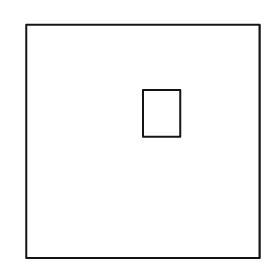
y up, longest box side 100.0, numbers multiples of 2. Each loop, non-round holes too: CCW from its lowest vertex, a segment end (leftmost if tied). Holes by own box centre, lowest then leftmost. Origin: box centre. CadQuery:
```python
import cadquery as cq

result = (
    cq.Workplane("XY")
    .moveTo(-50.0, -50.0)
    .lineTo(50.0, -50.0)
    .lineTo(50.0, 50.0)
    .lineTo(-50.0, 50.0)
    .close()
    .moveTo(0.0, 2.0)
    .lineTo(16.0, 2.0)
    .lineTo(16.0, 22.0)
    .lineTo(0.0, 22.0)
    .close()
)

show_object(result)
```